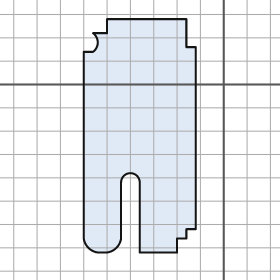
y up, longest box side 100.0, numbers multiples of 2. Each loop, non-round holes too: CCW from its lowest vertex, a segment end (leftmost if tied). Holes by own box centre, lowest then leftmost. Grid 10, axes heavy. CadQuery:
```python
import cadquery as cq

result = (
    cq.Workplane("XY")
    .moveTo(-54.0, -72.0)
    .lineTo(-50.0, -72.0)
    .threePointArc((-46.0, -70.0), (-44.0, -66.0))
    .lineTo(-44.0, -42.0)
    .threePointArc((-40.0, -38.0), (-36.0, -42.0))
    .lineTo(-36.0, -72.0)
    .lineTo(-20.0, -72.0)
    .lineTo(-20.0, -66.0)
    .lineTo(-16.0, -66.0)
    .lineTo(-16.0, -62.0)
    .lineTo(-12.0, -62.0)
    .lineTo(-12.0, 16.0)
    .lineTo(-16.0, 16.0)
    .lineTo(-16.0, 28.0)
    .lineTo(-50.0, 28.0)
    .lineTo(-50.0, 22.0)
    .lineTo(-56.0, 22.0)
    .threePointArc((-54.0, 18.0), (-56.0, 14.0))
    .lineTo(-60.0, 14.0)
    .lineTo(-60.0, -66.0)
    .threePointArc((-58.0, -70.0), (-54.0, -72.0))
    .close()
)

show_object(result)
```